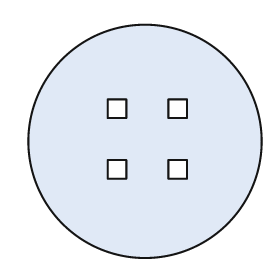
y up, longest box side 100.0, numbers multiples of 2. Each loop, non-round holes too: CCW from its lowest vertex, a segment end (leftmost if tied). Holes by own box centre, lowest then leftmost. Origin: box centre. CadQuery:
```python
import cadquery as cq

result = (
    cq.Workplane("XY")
    .moveTo(0.0, 0.0)
    .circle(50.0)
    .moveTo(-16.0, -16.0)
    .lineTo(-8.0, -16.0)
    .lineTo(-8.0, -8.0)
    .lineTo(-16.0, -8.0)
    .close()
    .moveTo(10.0, -16.0)
    .lineTo(18.0, -16.0)
    .lineTo(18.0, -8.0)
    .lineTo(10.0, -8.0)
    .close()
    .moveTo(-16.0, 10.0)
    .lineTo(-8.0, 10.0)
    .lineTo(-8.0, 18.0)
    .lineTo(-16.0, 18.0)
    .close()
    .moveTo(10.0, 10.0)
    .lineTo(18.0, 10.0)
    .lineTo(18.0, 18.0)
    .lineTo(10.0, 18.0)
    .close()
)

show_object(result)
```